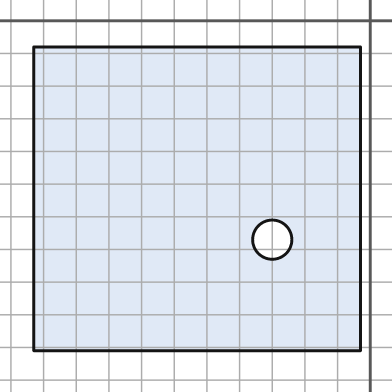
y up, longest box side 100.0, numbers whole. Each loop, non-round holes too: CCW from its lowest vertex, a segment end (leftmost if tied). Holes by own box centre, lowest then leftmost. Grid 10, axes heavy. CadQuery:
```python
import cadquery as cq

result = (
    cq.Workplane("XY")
    .moveTo(-103.0, -101.0)
    .lineTo(-3.0, -101.0)
    .lineTo(-3.0, -8.0)
    .lineTo(-103.0, -8.0)
    .close()
    .moveTo(-30.0, -67.0)
    .circle(6.0)
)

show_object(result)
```